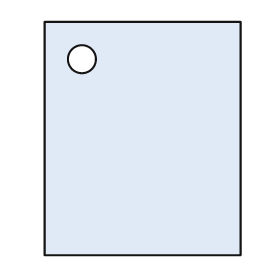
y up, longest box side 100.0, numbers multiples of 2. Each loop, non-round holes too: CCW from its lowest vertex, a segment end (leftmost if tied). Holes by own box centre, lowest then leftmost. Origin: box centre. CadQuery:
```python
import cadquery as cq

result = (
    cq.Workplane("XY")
    .moveTo(-42.0, -50.0)
    .lineTo(42.0, -50.0)
    .lineTo(42.0, 50.0)
    .lineTo(-42.0, 50.0)
    .close()
    .moveTo(-26.0, 34.0)
    .circle(6.0)
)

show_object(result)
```